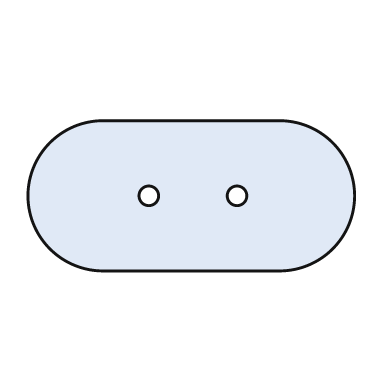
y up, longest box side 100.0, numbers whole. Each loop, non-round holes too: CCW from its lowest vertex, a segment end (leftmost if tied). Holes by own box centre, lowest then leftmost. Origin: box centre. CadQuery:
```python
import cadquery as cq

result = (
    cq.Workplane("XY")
    .moveTo(-27.0, -23.0)
    .lineTo(27.0, -23.0)
    .threePointArc((50.0, 0.0), (27.0, 23.0))
    .lineTo(-27.0, 23.0)
    .threePointArc((-50.0, 0.0), (-27.0, -23.0))
    .close()
    .moveTo(-13.0, 0.0)
    .circle(3.0)
    .moveTo(14.0, 0.0)
    .circle(3.0)
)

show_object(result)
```